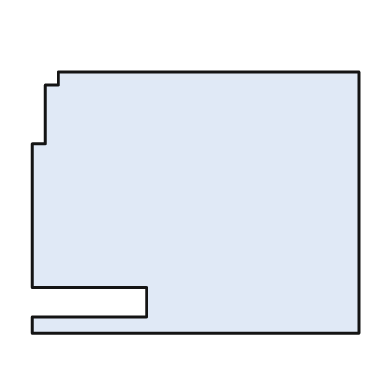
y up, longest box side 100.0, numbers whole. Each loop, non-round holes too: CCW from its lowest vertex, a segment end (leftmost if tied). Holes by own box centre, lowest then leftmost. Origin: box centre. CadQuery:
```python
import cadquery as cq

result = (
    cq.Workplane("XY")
    .moveTo(-50.0, -40.0)
    .lineTo(50.0, -40.0)
    .lineTo(50.0, 40.0)
    .lineTo(-42.0, 40.0)
    .lineTo(-42.0, 36.0)
    .lineTo(-46.0, 36.0)
    .lineTo(-46.0, 18.0)
    .lineTo(-50.0, 18.0)
    .lineTo(-50.0, -26.0)
    .lineTo(-15.0, -26.0)
    .lineTo(-15.0, -35.0)
    .lineTo(-50.0, -35.0)
    .close()
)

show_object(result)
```